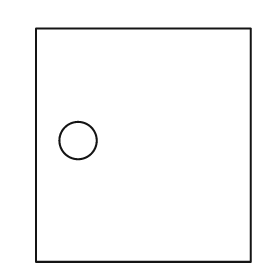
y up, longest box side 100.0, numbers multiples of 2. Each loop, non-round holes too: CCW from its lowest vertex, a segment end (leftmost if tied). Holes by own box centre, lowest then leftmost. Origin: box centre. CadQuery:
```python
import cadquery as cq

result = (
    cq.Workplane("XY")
    .moveTo(-46.0, -50.0)
    .lineTo(46.0, -50.0)
    .lineTo(46.0, 50.0)
    .lineTo(-46.0, 50.0)
    .close()
    .moveTo(-28.0, 2.0)
    .circle(8.0)
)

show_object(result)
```